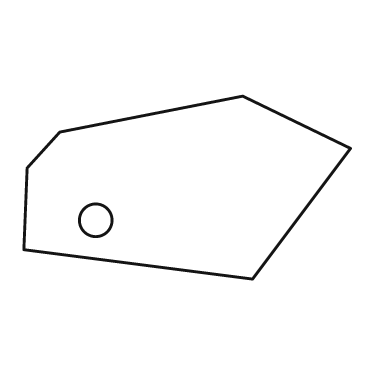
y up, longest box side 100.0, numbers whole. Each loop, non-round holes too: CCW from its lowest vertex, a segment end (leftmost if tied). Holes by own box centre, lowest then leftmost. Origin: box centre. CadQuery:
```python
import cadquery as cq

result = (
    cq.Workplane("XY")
    .moveTo(20.0, -28.0)
    .lineTo(50.0, 12.0)
    .lineTo(17.0, 28.0)
    .lineTo(-39.0, 17.0)
    .lineTo(-49.0, 6.0)
    .lineTo(-50.0, -19.0)
    .close()
    .moveTo(-28.0, -10.0)
    .circle(5.0)
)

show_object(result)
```